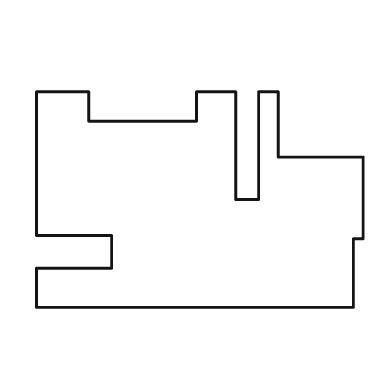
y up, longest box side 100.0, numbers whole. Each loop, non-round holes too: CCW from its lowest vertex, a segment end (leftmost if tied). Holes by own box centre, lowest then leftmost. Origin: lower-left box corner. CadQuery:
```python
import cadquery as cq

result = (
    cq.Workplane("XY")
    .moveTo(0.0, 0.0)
    .lineTo(97.0, 0.0)
    .lineTo(97.0, 21.0)
    .lineTo(100.0, 21.0)
    .lineTo(100.0, 46.0)
    .lineTo(74.0, 46.0)
    .lineTo(74.0, 66.0)
    .lineTo(68.0, 66.0)
    .lineTo(68.0, 33.0)
    .lineTo(61.0, 33.0)
    .lineTo(61.0, 66.0)
    .lineTo(49.0, 66.0)
    .lineTo(49.0, 57.0)
    .lineTo(16.0, 57.0)
    .lineTo(16.0, 66.0)
    .lineTo(0.0, 66.0)
    .lineTo(0.0, 22.0)
    .lineTo(23.0, 22.0)
    .lineTo(23.0, 12.0)
    .lineTo(0.0, 12.0)
    .close()
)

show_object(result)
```